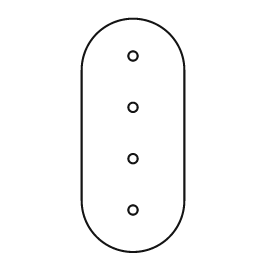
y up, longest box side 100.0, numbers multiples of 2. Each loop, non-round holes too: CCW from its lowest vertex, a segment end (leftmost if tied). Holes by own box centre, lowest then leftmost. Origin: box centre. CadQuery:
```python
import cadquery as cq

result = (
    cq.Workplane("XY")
    .moveTo(-22.0, -28.0)
    .threePointArc((0.0, -50.0), (22.0, -28.0))
    .lineTo(22.0, 28.0)
    .threePointArc((0.0, 50.0), (-22.0, 28.0))
    .close()
    .moveTo(0.0, -32.0)
    .circle(2.0)
    .moveTo(0.0, -10.0)
    .circle(2.0)
    .moveTo(0.0, 12.0)
    .circle(2.0)
    .moveTo(0.0, 34.0)
    .circle(2.0)
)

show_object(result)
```